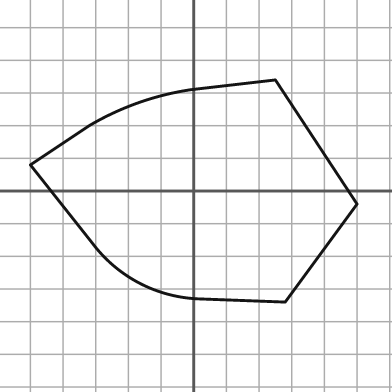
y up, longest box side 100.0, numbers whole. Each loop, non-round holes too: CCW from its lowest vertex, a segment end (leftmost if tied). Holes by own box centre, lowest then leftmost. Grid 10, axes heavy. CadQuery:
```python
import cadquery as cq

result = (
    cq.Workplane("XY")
    .moveTo(28.0, -34.0)
    .lineTo(50.0, -4.0)
    .lineTo(25.0, 34.0)
    .lineTo(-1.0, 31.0)
    .threePointArc((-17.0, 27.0), (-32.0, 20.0))
    .lineTo(-50.0, 8.0)
    .lineTo(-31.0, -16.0)
    .threePointArc((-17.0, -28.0), (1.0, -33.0))
    .close()
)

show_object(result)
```